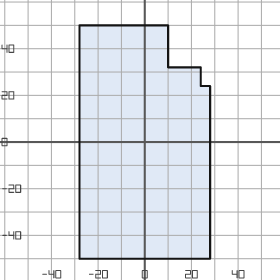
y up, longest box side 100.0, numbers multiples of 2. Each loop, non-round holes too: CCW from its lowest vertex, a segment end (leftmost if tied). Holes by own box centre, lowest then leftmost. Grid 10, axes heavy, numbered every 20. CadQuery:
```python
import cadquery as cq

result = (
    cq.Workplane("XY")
    .moveTo(-28.0, -50.0)
    .lineTo(28.0, -50.0)
    .lineTo(28.0, 24.0)
    .lineTo(24.0, 24.0)
    .lineTo(24.0, 32.0)
    .lineTo(10.0, 32.0)
    .lineTo(10.0, 50.0)
    .lineTo(-28.0, 50.0)
    .close()
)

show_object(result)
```